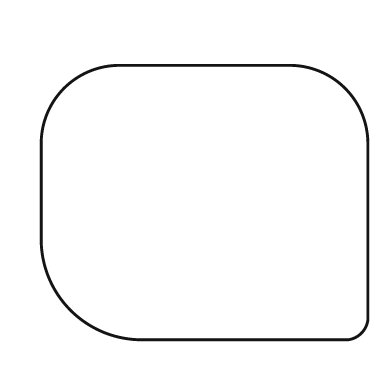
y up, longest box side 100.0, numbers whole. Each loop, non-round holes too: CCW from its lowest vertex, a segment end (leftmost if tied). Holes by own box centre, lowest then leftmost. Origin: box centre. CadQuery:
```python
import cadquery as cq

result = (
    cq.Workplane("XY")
    .moveTo(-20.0, -42.0)
    .lineTo(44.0, -42.0)
    .threePointArc((48.0, -40.0), (50.0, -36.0))
    .lineTo(50.0, 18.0)
    .threePointArc((43.0, 35.0), (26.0, 42.0))
    .lineTo(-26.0, 42.0)
    .threePointArc((-43.0, 35.0), (-50.0, 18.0))
    .lineTo(-50.0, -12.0)
    .threePointArc((-41.0, -33.0), (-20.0, -42.0))
    .close()
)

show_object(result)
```